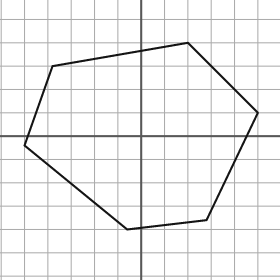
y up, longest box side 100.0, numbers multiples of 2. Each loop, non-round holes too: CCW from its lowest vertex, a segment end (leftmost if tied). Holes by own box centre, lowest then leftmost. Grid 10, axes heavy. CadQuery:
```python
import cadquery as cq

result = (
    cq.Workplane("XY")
    .moveTo(-6.0, -40.0)
    .lineTo(28.0, -36.0)
    .lineTo(50.0, 10.0)
    .lineTo(20.0, 40.0)
    .lineTo(-38.0, 30.0)
    .lineTo(-50.0, -4.0)
    .close()
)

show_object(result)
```